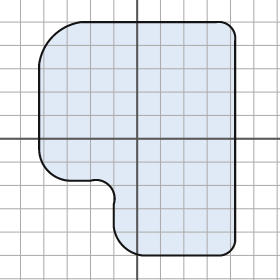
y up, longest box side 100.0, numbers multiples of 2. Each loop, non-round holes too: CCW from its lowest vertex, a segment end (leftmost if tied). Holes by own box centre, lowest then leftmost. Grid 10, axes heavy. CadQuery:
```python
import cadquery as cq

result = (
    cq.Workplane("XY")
    .moveTo(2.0, -50.0)
    .lineTo(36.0, -50.0)
    .threePointArc((40.0, -48.0), (42.0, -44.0))
    .lineTo(42.0, 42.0)
    .threePointArc((40.0, 48.0), (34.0, 50.0))
    .lineTo(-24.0, 50.0)
    .threePointArc((-36.0, 44.0), (-42.0, 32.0))
    .lineTo(-42.0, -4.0)
    .threePointArc((-38.0, -14.0), (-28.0, -18.0))
    .lineTo(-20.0, -18.0)
    .threePointArc((-12.0, -20.0), (-10.0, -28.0))
    .lineTo(-10.0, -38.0)
    .threePointArc((-6.0, -46.0), (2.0, -50.0))
    .close()
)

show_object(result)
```